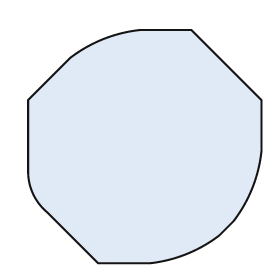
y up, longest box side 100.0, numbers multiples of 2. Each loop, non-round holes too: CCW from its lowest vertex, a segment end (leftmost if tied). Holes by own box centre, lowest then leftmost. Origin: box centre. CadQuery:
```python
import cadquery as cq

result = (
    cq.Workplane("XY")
    .moveTo(-20.0, -50.0)
    .lineTo(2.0, -50.0)
    .threePointArc((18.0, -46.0), (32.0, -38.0))
    .lineTo(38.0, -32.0)
    .threePointArc((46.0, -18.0), (50.0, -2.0))
    .lineTo(50.0, 20.0)
    .lineTo(20.0, 50.0)
    .lineTo(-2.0, 50.0)
    .threePointArc((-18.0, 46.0), (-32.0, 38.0))
    .lineTo(-50.0, 20.0)
    .lineTo(-50.0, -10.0)
    .threePointArc((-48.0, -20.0), (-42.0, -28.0))
    .close()
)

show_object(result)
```